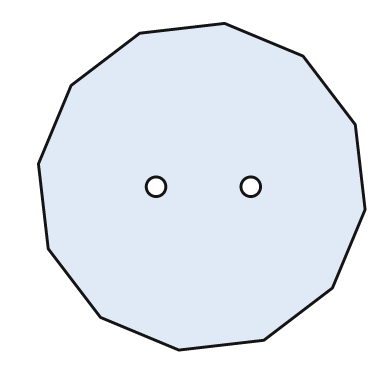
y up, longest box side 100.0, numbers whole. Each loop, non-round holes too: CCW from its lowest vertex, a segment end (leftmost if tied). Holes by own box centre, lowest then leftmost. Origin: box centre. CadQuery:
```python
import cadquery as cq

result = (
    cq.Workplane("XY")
    .moveTo(-7.0, -50.0)
    .lineTo(19.0, -47.0)
    .lineTo(40.0, -31.0)
    .lineTo(50.0, -7.0)
    .lineTo(47.0, 19.0)
    .lineTo(31.0, 40.0)
    .lineTo(7.0, 50.0)
    .lineTo(-19.0, 47.0)
    .lineTo(-40.0, 31.0)
    .lineTo(-50.0, 7.0)
    .lineTo(-47.0, -19.0)
    .lineTo(-31.0, -40.0)
    .close()
    .moveTo(-14.0, 0.0)
    .circle(3.0)
    .moveTo(15.0, 0.0)
    .circle(3.0)
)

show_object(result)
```